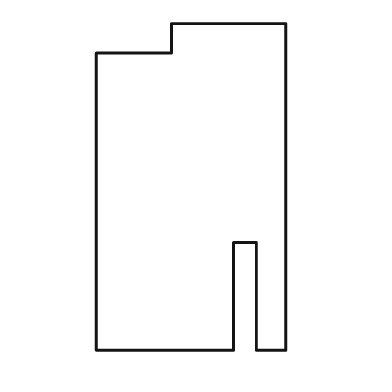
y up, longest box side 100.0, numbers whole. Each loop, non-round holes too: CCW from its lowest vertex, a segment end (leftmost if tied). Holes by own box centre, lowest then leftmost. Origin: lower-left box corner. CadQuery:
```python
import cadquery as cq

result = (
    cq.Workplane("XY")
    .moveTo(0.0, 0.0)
    .lineTo(42.0, 0.0)
    .lineTo(42.0, 33.0)
    .lineTo(49.0, 33.0)
    .lineTo(49.0, 0.0)
    .lineTo(58.0, 0.0)
    .lineTo(58.0, 100.0)
    .lineTo(23.0, 100.0)
    .lineTo(23.0, 91.0)
    .lineTo(0.0, 91.0)
    .close()
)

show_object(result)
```